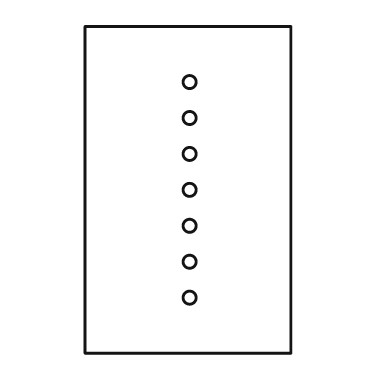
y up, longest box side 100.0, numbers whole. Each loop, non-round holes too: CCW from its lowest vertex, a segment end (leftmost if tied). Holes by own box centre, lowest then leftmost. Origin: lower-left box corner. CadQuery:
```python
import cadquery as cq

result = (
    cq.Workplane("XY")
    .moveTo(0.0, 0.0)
    .lineTo(63.0, 0.0)
    .lineTo(63.0, 100.0)
    .lineTo(0.0, 100.0)
    .close()
    .moveTo(32.0, 17.0)
    .circle(2.0)
    .moveTo(32.0, 28.0)
    .circle(2.0)
    .moveTo(32.0, 39.0)
    .circle(2.0)
    .moveTo(32.0, 50.0)
    .circle(2.0)
    .moveTo(32.0, 61.0)
    .circle(2.0)
    .moveTo(32.0, 72.0)
    .circle(2.0)
    .moveTo(32.0, 83.0)
    .circle(2.0)
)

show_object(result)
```